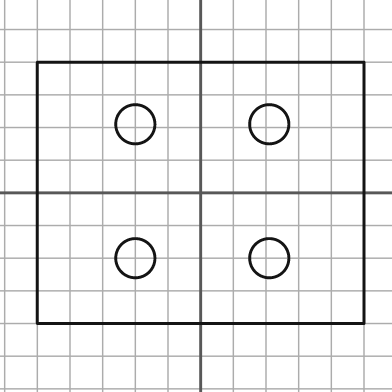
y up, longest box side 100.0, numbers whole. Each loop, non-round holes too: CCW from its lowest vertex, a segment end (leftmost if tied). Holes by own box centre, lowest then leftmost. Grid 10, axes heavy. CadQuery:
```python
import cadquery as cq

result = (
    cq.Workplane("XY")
    .moveTo(-50.0, -40.0)
    .lineTo(50.0, -40.0)
    .lineTo(50.0, 40.0)
    .lineTo(-50.0, 40.0)
    .close()
    .moveTo(-20.0, -20.0)
    .circle(6.0)
    .moveTo(21.0, -20.0)
    .circle(6.0)
    .moveTo(-20.0, 21.0)
    .circle(6.0)
    .moveTo(21.0, 21.0)
    .circle(6.0)
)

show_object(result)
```